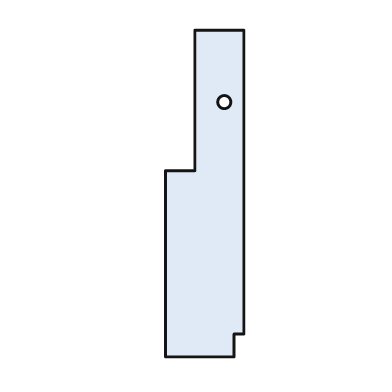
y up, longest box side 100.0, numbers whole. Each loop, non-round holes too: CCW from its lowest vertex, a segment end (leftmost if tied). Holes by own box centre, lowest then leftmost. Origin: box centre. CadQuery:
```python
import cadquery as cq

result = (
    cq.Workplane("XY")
    .moveTo(-12.0, -50.0)
    .lineTo(9.0, -50.0)
    .lineTo(9.0, -43.0)
    .lineTo(12.0, -43.0)
    .lineTo(12.0, 50.0)
    .lineTo(-3.0, 50.0)
    .lineTo(-3.0, 7.0)
    .lineTo(-12.0, 7.0)
    .close()
    .moveTo(6.0, 28.0)
    .circle(2.0)
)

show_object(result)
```